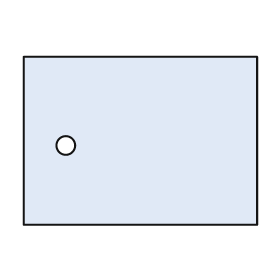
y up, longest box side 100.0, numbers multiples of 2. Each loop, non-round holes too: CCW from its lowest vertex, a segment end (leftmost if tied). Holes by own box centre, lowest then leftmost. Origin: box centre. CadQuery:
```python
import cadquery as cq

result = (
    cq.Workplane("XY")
    .moveTo(-50.0, -36.0)
    .lineTo(50.0, -36.0)
    .lineTo(50.0, 36.0)
    .lineTo(-50.0, 36.0)
    .close()
    .moveTo(-32.0, -2.0)
    .circle(4.0)
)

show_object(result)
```